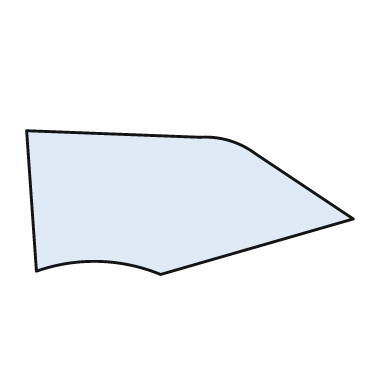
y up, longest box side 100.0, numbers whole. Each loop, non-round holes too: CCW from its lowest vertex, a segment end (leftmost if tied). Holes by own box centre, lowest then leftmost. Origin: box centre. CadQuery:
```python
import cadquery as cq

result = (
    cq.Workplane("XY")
    .moveTo(-9.0, -22.0)
    .lineTo(50.0, -5.0)
    .lineTo(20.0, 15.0)
    .threePointArc((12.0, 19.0), (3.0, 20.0))
    .lineTo(-50.0, 22.0)
    .lineTo(-47.0, -21.0)
    .threePointArc((-28.0, -18.0), (-9.0, -22.0))
    .close()
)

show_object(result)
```